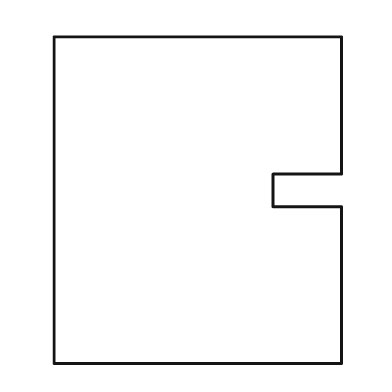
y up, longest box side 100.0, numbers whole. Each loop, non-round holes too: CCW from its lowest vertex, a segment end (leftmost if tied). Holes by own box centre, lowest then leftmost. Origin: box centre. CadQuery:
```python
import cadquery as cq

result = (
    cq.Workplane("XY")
    .moveTo(-44.0, -50.0)
    .lineTo(44.0, -50.0)
    .lineTo(44.0, -2.0)
    .lineTo(23.0, -2.0)
    .lineTo(23.0, 8.0)
    .lineTo(44.0, 8.0)
    .lineTo(44.0, 50.0)
    .lineTo(-44.0, 50.0)
    .close()
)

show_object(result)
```